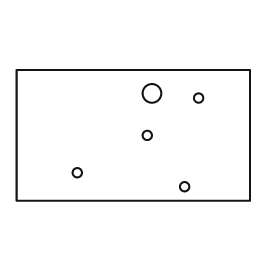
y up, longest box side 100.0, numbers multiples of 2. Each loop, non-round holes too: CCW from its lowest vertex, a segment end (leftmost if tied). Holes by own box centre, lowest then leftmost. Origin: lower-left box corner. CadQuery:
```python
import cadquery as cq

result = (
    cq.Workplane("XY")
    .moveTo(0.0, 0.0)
    .lineTo(100.0, 0.0)
    .lineTo(100.0, 56.0)
    .lineTo(0.0, 56.0)
    .close()
    .moveTo(72.0, 6.0)
    .circle(2.0)
    .moveTo(26.0, 12.0)
    .circle(2.0)
    .moveTo(56.0, 28.0)
    .circle(2.0)
    .moveTo(78.0, 44.0)
    .circle(2.0)
    .moveTo(58.0, 46.0)
    .circle(4.0)
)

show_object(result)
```